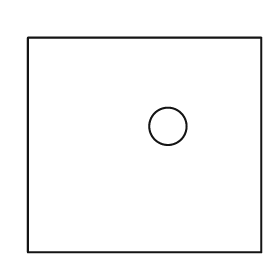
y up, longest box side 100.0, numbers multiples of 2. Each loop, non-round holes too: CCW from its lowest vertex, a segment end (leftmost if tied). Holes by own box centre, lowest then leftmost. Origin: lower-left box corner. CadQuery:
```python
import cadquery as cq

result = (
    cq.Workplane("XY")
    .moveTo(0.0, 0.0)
    .lineTo(100.0, 0.0)
    .lineTo(100.0, 92.0)
    .lineTo(0.0, 92.0)
    .close()
    .moveTo(60.0, 54.0)
    .circle(8.0)
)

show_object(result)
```